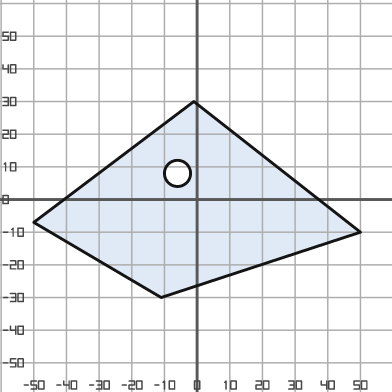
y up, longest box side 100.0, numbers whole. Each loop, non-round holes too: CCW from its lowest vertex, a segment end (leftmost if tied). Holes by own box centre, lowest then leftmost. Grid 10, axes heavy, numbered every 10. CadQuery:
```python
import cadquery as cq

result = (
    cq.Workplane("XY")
    .moveTo(-11.0, -30.0)
    .lineTo(50.0, -10.0)
    .lineTo(-1.0, 30.0)
    .lineTo(-50.0, -7.0)
    .close()
    .moveTo(-6.0, 8.0)
    .circle(4.0)
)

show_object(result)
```